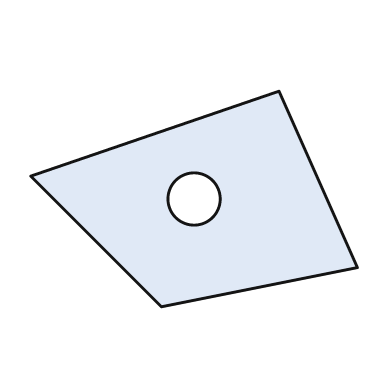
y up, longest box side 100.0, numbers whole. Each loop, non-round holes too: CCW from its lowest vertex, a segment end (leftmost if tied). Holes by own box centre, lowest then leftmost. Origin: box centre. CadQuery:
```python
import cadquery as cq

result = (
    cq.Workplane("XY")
    .moveTo(-10.0, -33.0)
    .lineTo(50.0, -21.0)
    .lineTo(26.0, 33.0)
    .lineTo(-50.0, 7.0)
    .close()
    .moveTo(0.0, 0.0)
    .circle(8.0)
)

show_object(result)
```